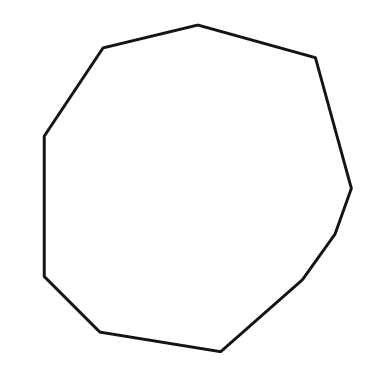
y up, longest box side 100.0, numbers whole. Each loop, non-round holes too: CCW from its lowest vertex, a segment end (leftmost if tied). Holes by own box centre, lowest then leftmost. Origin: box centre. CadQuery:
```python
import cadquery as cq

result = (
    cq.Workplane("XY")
    .moveTo(7.0, -50.0)
    .lineTo(32.0, -28.0)
    .lineTo(42.0, -14.0)
    .lineTo(47.0, 0.0)
    .lineTo(36.0, 40.0)
    .lineTo(0.0, 50.0)
    .lineTo(-29.0, 43.0)
    .lineTo(-47.0, 16.0)
    .lineTo(-47.0, -27.0)
    .lineTo(-30.0, -44.0)
    .close()
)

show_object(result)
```